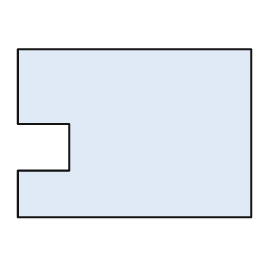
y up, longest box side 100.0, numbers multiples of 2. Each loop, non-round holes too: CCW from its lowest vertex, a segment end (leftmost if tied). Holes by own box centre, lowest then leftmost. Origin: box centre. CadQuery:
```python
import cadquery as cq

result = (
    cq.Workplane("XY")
    .moveTo(-50.0, -36.0)
    .lineTo(50.0, -36.0)
    .lineTo(50.0, 36.0)
    .lineTo(-50.0, 36.0)
    .lineTo(-50.0, 4.0)
    .lineTo(-28.0, 4.0)
    .lineTo(-28.0, -16.0)
    .lineTo(-50.0, -16.0)
    .close()
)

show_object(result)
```